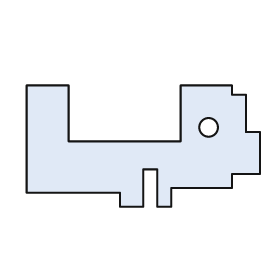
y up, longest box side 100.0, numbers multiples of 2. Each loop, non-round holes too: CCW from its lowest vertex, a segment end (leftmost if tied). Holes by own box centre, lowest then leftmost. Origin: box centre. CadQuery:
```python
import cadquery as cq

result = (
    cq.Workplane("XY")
    .moveTo(-10.0, -26.0)
    .lineTo(0.0, -26.0)
    .lineTo(0.0, -10.0)
    .lineTo(6.0, -10.0)
    .lineTo(6.0, -26.0)
    .lineTo(12.0, -26.0)
    .lineTo(12.0, -18.0)
    .lineTo(38.0, -18.0)
    .lineTo(38.0, -12.0)
    .lineTo(50.0, -12.0)
    .lineTo(50.0, 6.0)
    .lineTo(44.0, 6.0)
    .lineTo(44.0, 22.0)
    .lineTo(38.0, 22.0)
    .lineTo(38.0, 26.0)
    .lineTo(16.0, 26.0)
    .lineTo(16.0, 2.0)
    .lineTo(-32.0, 2.0)
    .lineTo(-32.0, 26.0)
    .lineTo(-50.0, 26.0)
    .lineTo(-50.0, -20.0)
    .lineTo(-10.0, -20.0)
    .close()
    .moveTo(28.0, 8.0)
    .circle(4.0)
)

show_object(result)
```